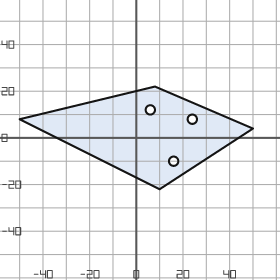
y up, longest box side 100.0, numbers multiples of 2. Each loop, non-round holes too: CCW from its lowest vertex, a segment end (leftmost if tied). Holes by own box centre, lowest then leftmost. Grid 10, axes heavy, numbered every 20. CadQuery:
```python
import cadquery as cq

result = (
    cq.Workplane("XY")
    .moveTo(10.0, -22.0)
    .lineTo(50.0, 4.0)
    .lineTo(8.0, 22.0)
    .lineTo(-50.0, 8.0)
    .close()
    .moveTo(16.0, -10.0)
    .circle(2.0)
    .moveTo(24.0, 8.0)
    .circle(2.0)
    .moveTo(6.0, 12.0)
    .circle(2.0)
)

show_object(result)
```